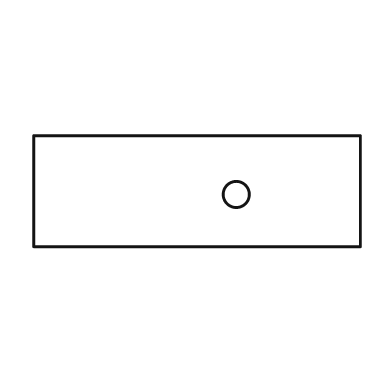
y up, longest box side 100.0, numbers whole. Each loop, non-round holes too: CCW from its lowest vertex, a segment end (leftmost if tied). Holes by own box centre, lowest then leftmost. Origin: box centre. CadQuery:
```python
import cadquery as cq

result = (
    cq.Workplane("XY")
    .moveTo(-50.0, -17.0)
    .lineTo(50.0, -17.0)
    .lineTo(50.0, 17.0)
    .lineTo(-50.0, 17.0)
    .close()
    .moveTo(12.0, -1.0)
    .circle(4.0)
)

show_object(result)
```